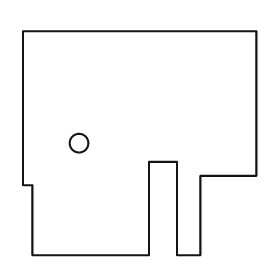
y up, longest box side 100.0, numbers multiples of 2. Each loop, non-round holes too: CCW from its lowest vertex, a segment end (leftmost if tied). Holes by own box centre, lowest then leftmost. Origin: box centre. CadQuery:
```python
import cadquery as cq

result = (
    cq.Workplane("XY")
    .moveTo(-46.0, -48.0)
    .lineTo(4.0, -48.0)
    .lineTo(4.0, -8.0)
    .lineTo(16.0, -8.0)
    .lineTo(16.0, -48.0)
    .lineTo(26.0, -48.0)
    .lineTo(26.0, -14.0)
    .lineTo(50.0, -14.0)
    .lineTo(50.0, 48.0)
    .lineTo(-50.0, 48.0)
    .lineTo(-50.0, -18.0)
    .lineTo(-46.0, -18.0)
    .close()
    .moveTo(-26.0, 0.0)
    .circle(4.0)
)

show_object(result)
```